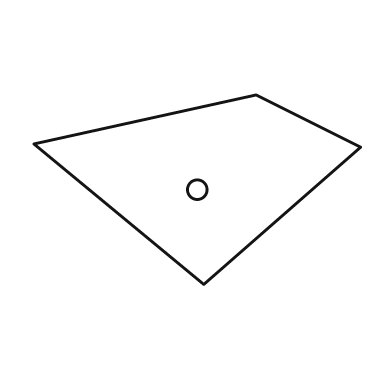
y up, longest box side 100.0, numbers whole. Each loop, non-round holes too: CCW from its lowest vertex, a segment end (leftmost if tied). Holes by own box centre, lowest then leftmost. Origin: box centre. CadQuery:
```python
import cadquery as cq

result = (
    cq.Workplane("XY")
    .moveTo(2.0, -29.0)
    .lineTo(50.0, 13.0)
    .lineTo(18.0, 29.0)
    .lineTo(-50.0, 14.0)
    .close()
    .moveTo(0.0, 0.0)
    .circle(3.0)
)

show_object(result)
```